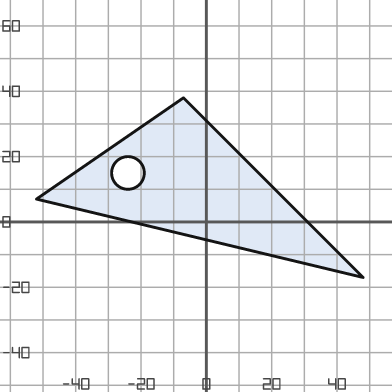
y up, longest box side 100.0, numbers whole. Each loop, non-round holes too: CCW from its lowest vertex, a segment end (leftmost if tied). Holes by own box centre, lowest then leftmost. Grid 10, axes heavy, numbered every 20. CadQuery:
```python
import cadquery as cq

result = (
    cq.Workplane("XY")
    .moveTo(48.0, -17.0)
    .lineTo(-7.0, 38.0)
    .lineTo(-52.0, 7.0)
    .close()
    .moveTo(-24.0, 15.0)
    .circle(5.0)
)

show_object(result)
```